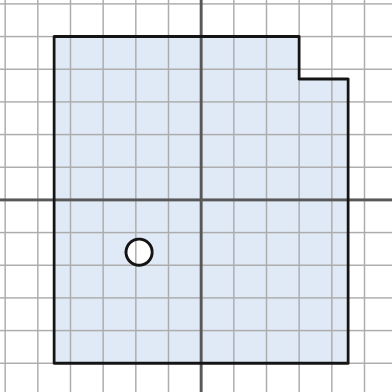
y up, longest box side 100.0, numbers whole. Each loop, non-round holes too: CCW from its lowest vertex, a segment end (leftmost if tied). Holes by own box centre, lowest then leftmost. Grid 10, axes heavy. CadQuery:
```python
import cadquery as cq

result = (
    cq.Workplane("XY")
    .moveTo(-45.0, -50.0)
    .lineTo(45.0, -50.0)
    .lineTo(45.0, 37.0)
    .lineTo(30.0, 37.0)
    .lineTo(30.0, 50.0)
    .lineTo(-45.0, 50.0)
    .close()
    .moveTo(-19.0, -16.0)
    .circle(4.0)
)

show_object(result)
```